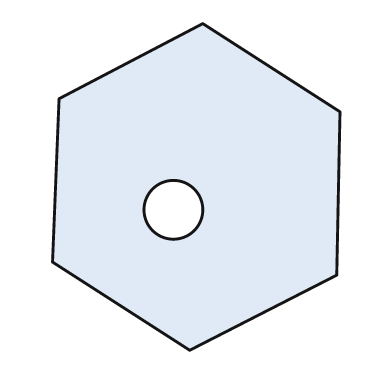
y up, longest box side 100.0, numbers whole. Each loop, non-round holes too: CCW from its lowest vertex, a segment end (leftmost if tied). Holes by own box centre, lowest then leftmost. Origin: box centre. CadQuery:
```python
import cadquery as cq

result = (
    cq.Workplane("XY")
    .moveTo(-2.0, -50.0)
    .lineTo(43.0, -27.0)
    .lineTo(44.0, 23.0)
    .lineTo(2.0, 50.0)
    .lineTo(-42.0, 27.0)
    .lineTo(-44.0, -23.0)
    .close()
    .moveTo(-7.0, -7.0)
    .circle(9.0)
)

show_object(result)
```